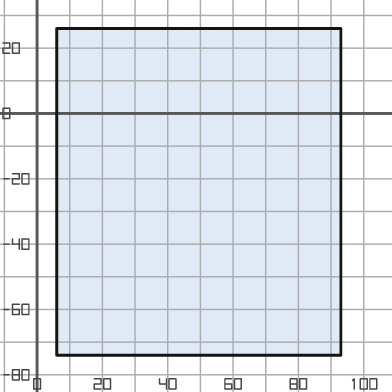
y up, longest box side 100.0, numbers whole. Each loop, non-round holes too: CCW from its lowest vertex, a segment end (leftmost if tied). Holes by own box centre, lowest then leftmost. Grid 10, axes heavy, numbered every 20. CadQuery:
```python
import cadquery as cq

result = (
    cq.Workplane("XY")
    .moveTo(6.0, -74.0)
    .lineTo(93.0, -74.0)
    .lineTo(93.0, 26.0)
    .lineTo(6.0, 26.0)
    .close()
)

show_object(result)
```